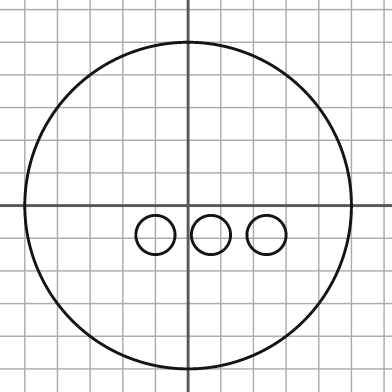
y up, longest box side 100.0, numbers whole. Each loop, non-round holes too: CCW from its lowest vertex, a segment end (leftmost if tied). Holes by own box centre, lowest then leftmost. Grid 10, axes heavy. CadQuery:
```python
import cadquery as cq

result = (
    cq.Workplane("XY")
    .moveTo(0.0, 0.0)
    .circle(50.0)
    .moveTo(-10.0, -9.0)
    .circle(6.0)
    .moveTo(7.0, -9.0)
    .circle(6.0)
    .moveTo(24.0, -9.0)
    .circle(6.0)
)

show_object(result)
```